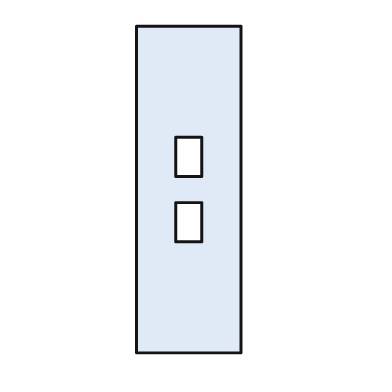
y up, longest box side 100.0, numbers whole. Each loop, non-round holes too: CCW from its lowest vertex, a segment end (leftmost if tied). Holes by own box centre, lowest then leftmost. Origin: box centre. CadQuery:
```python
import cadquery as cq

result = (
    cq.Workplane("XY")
    .moveTo(-16.0, -50.0)
    .lineTo(16.0, -50.0)
    .lineTo(16.0, 50.0)
    .lineTo(-16.0, 50.0)
    .close()
    .moveTo(-4.0, -16.0)
    .lineTo(4.0, -16.0)
    .lineTo(4.0, -4.0)
    .lineTo(-4.0, -4.0)
    .close()
    .moveTo(-4.0, 4.0)
    .lineTo(4.0, 4.0)
    .lineTo(4.0, 16.0)
    .lineTo(-4.0, 16.0)
    .close()
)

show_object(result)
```